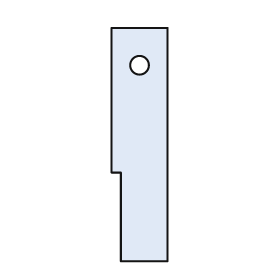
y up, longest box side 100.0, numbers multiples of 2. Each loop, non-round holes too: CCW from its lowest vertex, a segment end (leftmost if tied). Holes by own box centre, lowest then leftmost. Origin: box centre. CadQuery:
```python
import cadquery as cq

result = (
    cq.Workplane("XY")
    .moveTo(-8.0, -50.0)
    .lineTo(12.0, -50.0)
    .lineTo(12.0, 50.0)
    .lineTo(-12.0, 50.0)
    .lineTo(-12.0, -12.0)
    .lineTo(-8.0, -12.0)
    .close()
    .moveTo(0.0, 34.0)
    .circle(4.0)
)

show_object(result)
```